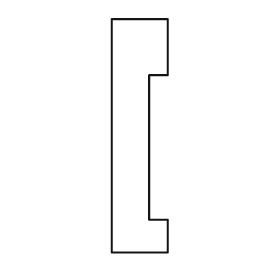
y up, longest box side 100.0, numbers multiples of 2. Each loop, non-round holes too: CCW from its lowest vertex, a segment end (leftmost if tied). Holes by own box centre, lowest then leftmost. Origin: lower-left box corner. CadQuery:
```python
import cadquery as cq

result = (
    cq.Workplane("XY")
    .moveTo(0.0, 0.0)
    .lineTo(24.0, 0.0)
    .lineTo(24.0, 14.0)
    .lineTo(16.0, 14.0)
    .lineTo(16.0, 76.0)
    .lineTo(24.0, 76.0)
    .lineTo(24.0, 100.0)
    .lineTo(0.0, 100.0)
    .close()
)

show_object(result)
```